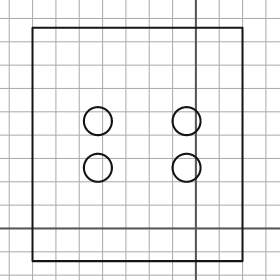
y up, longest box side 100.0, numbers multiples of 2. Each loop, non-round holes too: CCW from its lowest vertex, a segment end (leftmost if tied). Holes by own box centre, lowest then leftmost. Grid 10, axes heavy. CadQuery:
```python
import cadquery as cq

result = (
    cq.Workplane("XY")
    .moveTo(-70.0, -14.0)
    .lineTo(20.0, -14.0)
    .lineTo(20.0, 86.0)
    .lineTo(-70.0, 86.0)
    .close()
    .moveTo(-42.0, 26.0)
    .circle(6.0)
    .moveTo(-4.0, 26.0)
    .circle(6.0)
    .moveTo(-42.0, 46.0)
    .circle(6.0)
    .moveTo(-4.0, 46.0)
    .circle(6.0)
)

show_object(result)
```